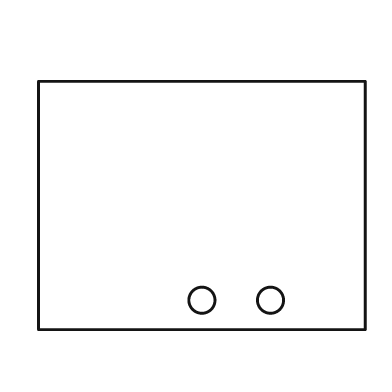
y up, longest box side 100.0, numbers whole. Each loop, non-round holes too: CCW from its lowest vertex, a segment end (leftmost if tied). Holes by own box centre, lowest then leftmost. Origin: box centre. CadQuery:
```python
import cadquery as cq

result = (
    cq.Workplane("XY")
    .moveTo(-50.0, -38.0)
    .lineTo(50.0, -38.0)
    .lineTo(50.0, 38.0)
    .lineTo(-50.0, 38.0)
    .close()
    .moveTo(0.0, -29.0)
    .circle(4.0)
    .moveTo(21.0, -29.0)
    .circle(4.0)
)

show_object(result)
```